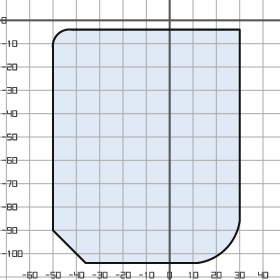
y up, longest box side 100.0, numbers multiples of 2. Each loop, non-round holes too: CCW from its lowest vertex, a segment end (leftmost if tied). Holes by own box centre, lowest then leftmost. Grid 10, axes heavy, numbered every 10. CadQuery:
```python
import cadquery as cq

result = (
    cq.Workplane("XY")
    .moveTo(-36.0, -104.0)
    .lineTo(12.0, -104.0)
    .threePointArc((24.0, -98.0), (30.0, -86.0))
    .lineTo(30.0, -4.0)
    .lineTo(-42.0, -4.0)
    .threePointArc((-48.0, -6.0), (-50.0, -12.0))
    .lineTo(-50.0, -90.0)
    .close()
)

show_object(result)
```